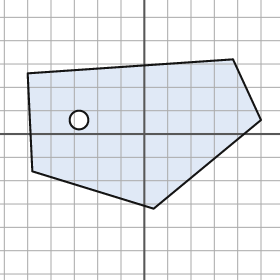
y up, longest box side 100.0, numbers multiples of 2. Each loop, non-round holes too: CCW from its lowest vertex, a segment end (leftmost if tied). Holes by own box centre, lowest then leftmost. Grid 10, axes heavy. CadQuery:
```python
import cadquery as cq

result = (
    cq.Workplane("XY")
    .moveTo(4.0, -32.0)
    .lineTo(50.0, 6.0)
    .lineTo(38.0, 32.0)
    .lineTo(-50.0, 26.0)
    .lineTo(-48.0, -16.0)
    .close()
    .moveTo(-28.0, 6.0)
    .circle(4.0)
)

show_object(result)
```